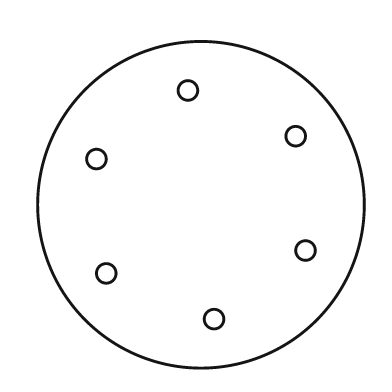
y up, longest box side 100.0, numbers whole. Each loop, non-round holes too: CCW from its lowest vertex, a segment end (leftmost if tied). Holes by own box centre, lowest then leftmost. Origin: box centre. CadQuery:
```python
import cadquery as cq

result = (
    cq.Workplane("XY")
    .moveTo(0.0, 0.0)
    .circle(50.0)
    .moveTo(4.0, -35.0)
    .circle(3.0)
    .moveTo(-29.0, -21.0)
    .circle(3.0)
    .moveTo(32.0, -14.0)
    .circle(3.0)
    .moveTo(-32.0, 14.0)
    .circle(3.0)
    .moveTo(29.0, 21.0)
    .circle(3.0)
    .moveTo(-4.0, 35.0)
    .circle(3.0)
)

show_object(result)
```